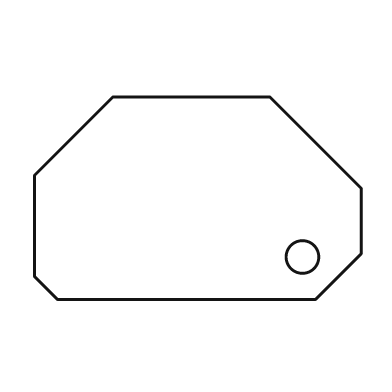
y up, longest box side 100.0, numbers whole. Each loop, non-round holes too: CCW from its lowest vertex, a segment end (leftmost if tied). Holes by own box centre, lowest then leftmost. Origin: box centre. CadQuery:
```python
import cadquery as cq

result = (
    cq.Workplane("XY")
    .moveTo(-43.0, -31.0)
    .lineTo(36.0, -31.0)
    .lineTo(50.0, -17.0)
    .lineTo(50.0, 3.0)
    .lineTo(22.0, 31.0)
    .lineTo(-26.0, 31.0)
    .lineTo(-50.0, 7.0)
    .lineTo(-50.0, -24.0)
    .close()
    .moveTo(32.0, -18.0)
    .circle(5.0)
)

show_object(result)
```